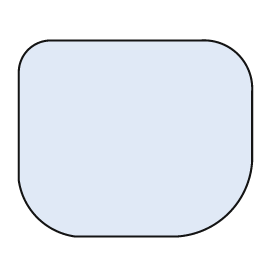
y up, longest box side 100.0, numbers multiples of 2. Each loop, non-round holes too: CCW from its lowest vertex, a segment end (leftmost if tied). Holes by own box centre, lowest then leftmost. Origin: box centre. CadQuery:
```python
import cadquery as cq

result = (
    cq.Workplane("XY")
    .moveTo(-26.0, -42.0)
    .lineTo(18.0, -42.0)
    .threePointArc((40.0, -32.0), (50.0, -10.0))
    .lineTo(50.0, 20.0)
    .threePointArc((44.0, 36.0), (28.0, 42.0))
    .lineTo(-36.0, 42.0)
    .threePointArc((-46.0, 38.0), (-50.0, 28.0))
    .lineTo(-50.0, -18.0)
    .threePointArc((-42.0, -34.0), (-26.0, -42.0))
    .close()
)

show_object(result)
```